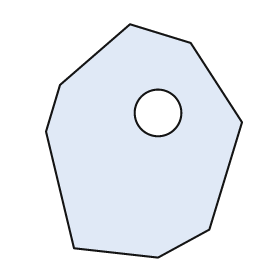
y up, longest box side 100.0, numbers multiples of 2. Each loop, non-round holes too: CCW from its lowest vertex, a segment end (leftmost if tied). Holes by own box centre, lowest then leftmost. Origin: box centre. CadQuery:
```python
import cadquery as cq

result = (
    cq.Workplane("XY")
    .moveTo(6.0, -50.0)
    .lineTo(28.0, -38.0)
    .lineTo(42.0, 8.0)
    .lineTo(20.0, 42.0)
    .lineTo(-6.0, 50.0)
    .lineTo(-36.0, 24.0)
    .lineTo(-42.0, 4.0)
    .lineTo(-30.0, -46.0)
    .close()
    .moveTo(6.0, 12.0)
    .circle(10.0)
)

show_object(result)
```